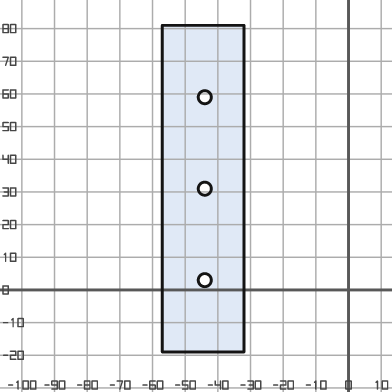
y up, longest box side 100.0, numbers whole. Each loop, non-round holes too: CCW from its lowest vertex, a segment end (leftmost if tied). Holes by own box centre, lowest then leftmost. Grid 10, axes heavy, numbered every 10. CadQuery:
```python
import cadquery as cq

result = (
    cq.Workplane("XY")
    .moveTo(-57.0, -19.0)
    .lineTo(-32.0, -19.0)
    .lineTo(-32.0, 81.0)
    .lineTo(-57.0, 81.0)
    .close()
    .moveTo(-44.0, 3.0)
    .circle(2.0)
    .moveTo(-44.0, 31.0)
    .circle(2.0)
    .moveTo(-44.0, 59.0)
    .circle(2.0)
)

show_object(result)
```